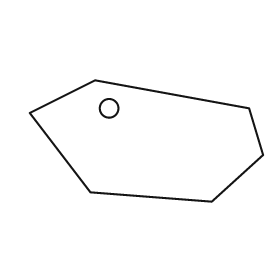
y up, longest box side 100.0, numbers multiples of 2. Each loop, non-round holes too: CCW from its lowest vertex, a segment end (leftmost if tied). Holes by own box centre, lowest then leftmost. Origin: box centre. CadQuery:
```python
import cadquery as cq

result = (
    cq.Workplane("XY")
    .moveTo(28.0, -26.0)
    .lineTo(50.0, -6.0)
    .lineTo(44.0, 14.0)
    .lineTo(-22.0, 26.0)
    .lineTo(-50.0, 12.0)
    .lineTo(-24.0, -22.0)
    .close()
    .moveTo(-16.0, 14.0)
    .circle(4.0)
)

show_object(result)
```